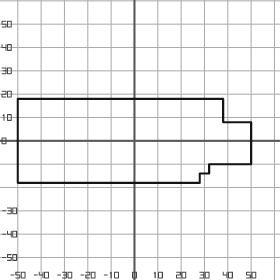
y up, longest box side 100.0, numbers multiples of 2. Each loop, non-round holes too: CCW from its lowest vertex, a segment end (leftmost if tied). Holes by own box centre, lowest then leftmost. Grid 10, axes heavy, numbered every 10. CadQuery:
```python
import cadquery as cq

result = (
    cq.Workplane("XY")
    .moveTo(-50.0, -18.0)
    .lineTo(28.0, -18.0)
    .lineTo(28.0, -14.0)
    .lineTo(32.0, -14.0)
    .lineTo(32.0, -10.0)
    .lineTo(50.0, -10.0)
    .lineTo(50.0, 8.0)
    .lineTo(38.0, 8.0)
    .lineTo(38.0, 18.0)
    .lineTo(-50.0, 18.0)
    .close()
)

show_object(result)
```